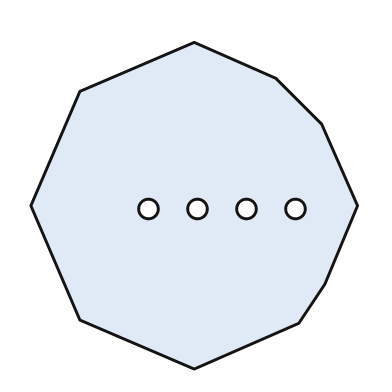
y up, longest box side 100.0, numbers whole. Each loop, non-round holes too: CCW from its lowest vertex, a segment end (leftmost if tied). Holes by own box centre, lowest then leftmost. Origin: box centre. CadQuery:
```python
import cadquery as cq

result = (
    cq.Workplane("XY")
    .moveTo(0.0, -50.0)
    .lineTo(32.0, -36.0)
    .lineTo(40.0, -24.0)
    .lineTo(50.0, 0.0)
    .lineTo(39.0, 25.0)
    .lineTo(25.0, 39.0)
    .lineTo(0.0, 50.0)
    .lineTo(-35.0, 35.0)
    .lineTo(-50.0, 0.0)
    .lineTo(-35.0, -35.0)
    .close()
    .moveTo(-14.0, -1.0)
    .circle(3.0)
    .moveTo(1.0, -1.0)
    .circle(3.0)
    .moveTo(16.0, -1.0)
    .circle(3.0)
    .moveTo(31.0, -1.0)
    .circle(3.0)
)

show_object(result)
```